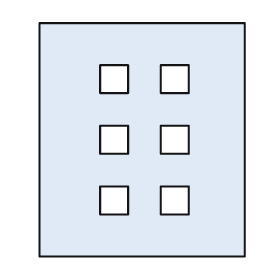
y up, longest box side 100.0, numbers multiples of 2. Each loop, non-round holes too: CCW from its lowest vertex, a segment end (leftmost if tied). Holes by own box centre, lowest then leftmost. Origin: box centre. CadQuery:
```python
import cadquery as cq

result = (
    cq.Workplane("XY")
    .moveTo(-44.0, -50.0)
    .lineTo(44.0, -50.0)
    .lineTo(44.0, 50.0)
    .lineTo(-44.0, 50.0)
    .close()
    .moveTo(-18.0, -32.0)
    .lineTo(-6.0, -32.0)
    .lineTo(-6.0, -20.0)
    .lineTo(-18.0, -20.0)
    .close()
    .moveTo(8.0, -32.0)
    .lineTo(20.0, -32.0)
    .lineTo(20.0, -20.0)
    .lineTo(8.0, -20.0)
    .close()
    .moveTo(-18.0, -6.0)
    .lineTo(-6.0, -6.0)
    .lineTo(-6.0, 6.0)
    .lineTo(-18.0, 6.0)
    .close()
    .moveTo(8.0, -6.0)
    .lineTo(20.0, -6.0)
    .lineTo(20.0, 6.0)
    .lineTo(8.0, 6.0)
    .close()
    .moveTo(-18.0, 20.0)
    .lineTo(-6.0, 20.0)
    .lineTo(-6.0, 32.0)
    .lineTo(-18.0, 32.0)
    .close()
    .moveTo(8.0, 20.0)
    .lineTo(20.0, 20.0)
    .lineTo(20.0, 32.0)
    .lineTo(8.0, 32.0)
    .close()
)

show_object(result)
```